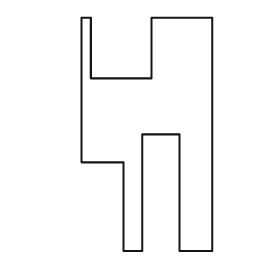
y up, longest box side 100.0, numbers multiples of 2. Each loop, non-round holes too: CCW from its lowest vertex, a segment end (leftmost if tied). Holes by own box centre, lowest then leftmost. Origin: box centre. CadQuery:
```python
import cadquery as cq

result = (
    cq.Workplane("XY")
    .moveTo(-10.0, -50.0)
    .lineTo(-2.0, -50.0)
    .lineTo(-2.0, 0.0)
    .lineTo(14.0, 0.0)
    .lineTo(14.0, -50.0)
    .lineTo(28.0, -50.0)
    .lineTo(28.0, 50.0)
    .lineTo(2.0, 50.0)
    .lineTo(2.0, 24.0)
    .lineTo(-24.0, 24.0)
    .lineTo(-24.0, 50.0)
    .lineTo(-28.0, 50.0)
    .lineTo(-28.0, -12.0)
    .lineTo(-10.0, -12.0)
    .close()
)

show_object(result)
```